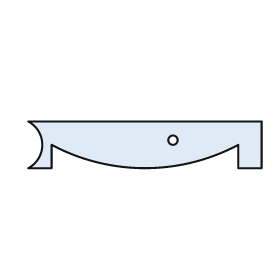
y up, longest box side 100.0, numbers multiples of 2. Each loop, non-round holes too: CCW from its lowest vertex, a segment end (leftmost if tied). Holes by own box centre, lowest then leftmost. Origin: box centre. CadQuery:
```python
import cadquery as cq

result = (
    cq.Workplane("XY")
    .moveTo(-50.0, -10.0)
    .lineTo(-40.0, -10.0)
    .lineTo(-40.0, 0.0)
    .threePointArc((0.0, -10.0), (40.0, 0.0))
    .lineTo(40.0, -10.0)
    .lineTo(50.0, -10.0)
    .lineTo(50.0, 10.0)
    .lineTo(-50.0, 10.0)
    .threePointArc((-44.0, 0.0), (-50.0, -10.0))
    .close()
    .moveTo(12.0, 2.0)
    .circle(2.0)
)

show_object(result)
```